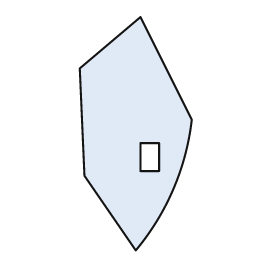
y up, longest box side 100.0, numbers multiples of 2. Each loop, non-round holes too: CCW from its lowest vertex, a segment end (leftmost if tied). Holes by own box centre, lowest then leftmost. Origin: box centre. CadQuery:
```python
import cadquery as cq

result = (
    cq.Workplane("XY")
    .moveTo(0.0, -50.0)
    .threePointArc((16.0, -24.0), (24.0, 6.0))
    .lineTo(2.0, 50.0)
    .lineTo(-24.0, 28.0)
    .lineTo(-22.0, -18.0)
    .close()
    .moveTo(2.0, -16.0)
    .lineTo(10.0, -16.0)
    .lineTo(10.0, -4.0)
    .lineTo(2.0, -4.0)
    .close()
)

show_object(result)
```